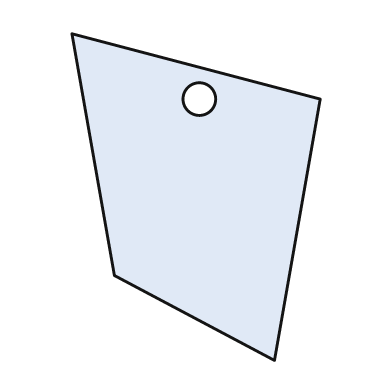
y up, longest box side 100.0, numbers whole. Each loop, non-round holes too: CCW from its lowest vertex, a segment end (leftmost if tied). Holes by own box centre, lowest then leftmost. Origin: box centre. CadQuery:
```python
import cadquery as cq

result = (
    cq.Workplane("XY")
    .moveTo(24.0, -50.0)
    .lineTo(38.0, 30.0)
    .lineTo(-38.0, 50.0)
    .lineTo(-25.0, -24.0)
    .close()
    .moveTo(1.0, 30.0)
    .circle(5.0)
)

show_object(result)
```